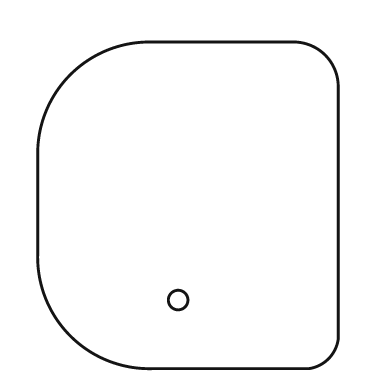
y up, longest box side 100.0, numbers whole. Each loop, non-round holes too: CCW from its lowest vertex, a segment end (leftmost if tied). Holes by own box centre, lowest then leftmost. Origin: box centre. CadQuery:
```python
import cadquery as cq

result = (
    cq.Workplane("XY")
    .moveTo(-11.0, -50.0)
    .lineTo(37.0, -50.0)
    .threePointArc((43.0, -47.0), (46.0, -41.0))
    .lineTo(46.0, 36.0)
    .threePointArc((42.0, 46.0), (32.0, 50.0))
    .lineTo(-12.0, 50.0)
    .threePointArc((-36.0, 40.0), (-46.0, 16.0))
    .lineTo(-46.0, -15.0)
    .threePointArc((-36.0, -40.0), (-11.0, -50.0))
    .close()
    .moveTo(-3.0, -29.0)
    .circle(3.0)
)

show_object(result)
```